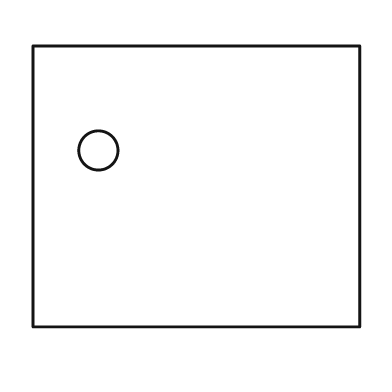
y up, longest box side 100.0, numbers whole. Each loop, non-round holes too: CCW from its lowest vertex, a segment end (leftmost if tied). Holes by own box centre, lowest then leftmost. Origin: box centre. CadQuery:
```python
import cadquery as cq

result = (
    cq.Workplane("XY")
    .moveTo(-50.0, -43.0)
    .lineTo(50.0, -43.0)
    .lineTo(50.0, 43.0)
    .lineTo(-50.0, 43.0)
    .close()
    .moveTo(-30.0, 11.0)
    .circle(6.0)
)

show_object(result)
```